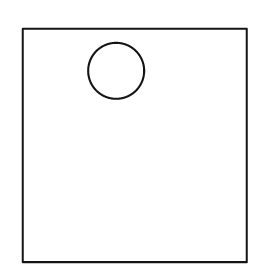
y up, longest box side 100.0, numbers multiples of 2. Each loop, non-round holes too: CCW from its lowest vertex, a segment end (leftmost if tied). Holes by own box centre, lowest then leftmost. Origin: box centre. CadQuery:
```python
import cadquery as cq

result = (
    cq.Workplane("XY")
    .moveTo(-48.0, -50.0)
    .lineTo(48.0, -50.0)
    .lineTo(48.0, 50.0)
    .lineTo(-48.0, 50.0)
    .close()
    .moveTo(-8.0, 32.0)
    .circle(12.0)
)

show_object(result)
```